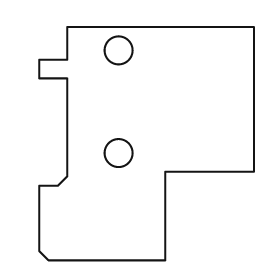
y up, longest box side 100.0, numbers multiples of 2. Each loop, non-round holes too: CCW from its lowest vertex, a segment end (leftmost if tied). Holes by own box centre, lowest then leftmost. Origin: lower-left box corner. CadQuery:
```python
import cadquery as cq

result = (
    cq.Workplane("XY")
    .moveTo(4.0, 0.0)
    .lineTo(54.0, 0.0)
    .lineTo(54.0, 38.0)
    .lineTo(92.0, 38.0)
    .lineTo(92.0, 100.0)
    .lineTo(12.0, 100.0)
    .lineTo(12.0, 86.0)
    .lineTo(0.0, 86.0)
    .lineTo(0.0, 78.0)
    .lineTo(12.0, 78.0)
    .lineTo(12.0, 36.0)
    .lineTo(8.0, 32.0)
    .lineTo(0.0, 32.0)
    .lineTo(0.0, 4.0)
    .close()
    .moveTo(34.0, 46.0)
    .circle(6.0)
    .moveTo(34.0, 90.0)
    .circle(6.0)
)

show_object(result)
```